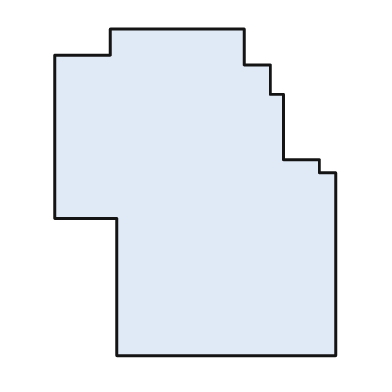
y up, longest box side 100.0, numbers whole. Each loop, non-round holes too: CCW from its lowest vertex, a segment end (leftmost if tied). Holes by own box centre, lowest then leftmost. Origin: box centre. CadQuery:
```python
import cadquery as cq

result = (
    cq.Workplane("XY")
    .moveTo(-24.0, -50.0)
    .lineTo(43.0, -50.0)
    .lineTo(43.0, 6.0)
    .lineTo(38.0, 6.0)
    .lineTo(38.0, 10.0)
    .lineTo(27.0, 10.0)
    .lineTo(27.0, 30.0)
    .lineTo(23.0, 30.0)
    .lineTo(23.0, 39.0)
    .lineTo(15.0, 39.0)
    .lineTo(15.0, 50.0)
    .lineTo(-26.0, 50.0)
    .lineTo(-26.0, 42.0)
    .lineTo(-43.0, 42.0)
    .lineTo(-43.0, -8.0)
    .lineTo(-24.0, -8.0)
    .close()
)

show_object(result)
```